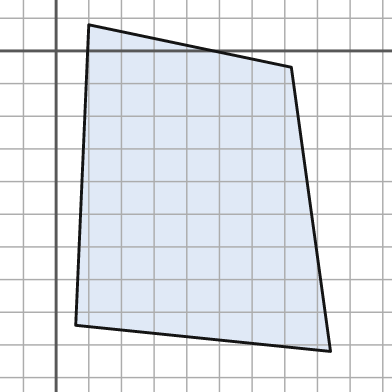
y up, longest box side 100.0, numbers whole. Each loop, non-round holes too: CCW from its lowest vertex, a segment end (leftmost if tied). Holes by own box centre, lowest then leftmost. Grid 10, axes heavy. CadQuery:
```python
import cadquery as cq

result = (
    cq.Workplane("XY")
    .moveTo(84.0, -92.0)
    .lineTo(72.0, -5.0)
    .lineTo(10.0, 8.0)
    .lineTo(6.0, -84.0)
    .close()
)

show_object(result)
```